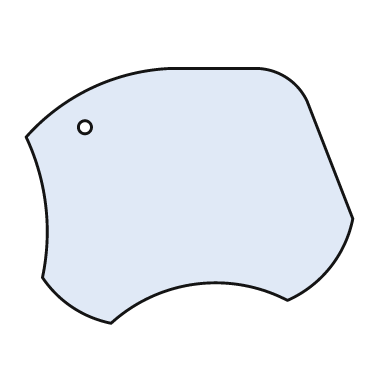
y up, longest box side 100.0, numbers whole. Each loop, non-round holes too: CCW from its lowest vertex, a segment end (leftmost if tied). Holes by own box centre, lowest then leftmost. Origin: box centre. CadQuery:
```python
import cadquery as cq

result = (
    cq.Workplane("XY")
    .moveTo(-24.0, -39.0)
    .threePointArc((2.0, -27.0), (30.0, -32.0))
    .threePointArc((43.0, -22.0), (50.0, -7.0))
    .lineTo(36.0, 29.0)
    .threePointArc((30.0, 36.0), (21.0, 39.0))
    .lineTo(-6.0, 39.0)
    .threePointArc((-30.0, 33.0), (-50.0, 18.0))
    .threePointArc((-44.0, -3.0), (-45.0, -25.0))
    .threePointArc((-36.0, -34.0), (-24.0, -39.0))
    .close()
    .moveTo(-32.0, 21.0)
    .circle(2.0)
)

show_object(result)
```